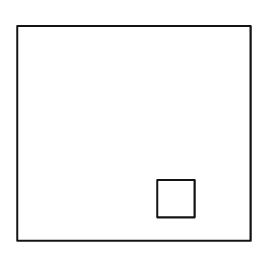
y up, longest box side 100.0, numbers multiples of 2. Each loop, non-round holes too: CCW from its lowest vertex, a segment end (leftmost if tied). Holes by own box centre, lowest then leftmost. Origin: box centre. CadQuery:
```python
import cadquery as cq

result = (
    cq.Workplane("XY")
    .moveTo(-50.0, -46.0)
    .lineTo(50.0, -46.0)
    .lineTo(50.0, 46.0)
    .lineTo(-50.0, 46.0)
    .close()
    .moveTo(10.0, -36.0)
    .lineTo(26.0, -36.0)
    .lineTo(26.0, -20.0)
    .lineTo(10.0, -20.0)
    .close()
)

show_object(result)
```